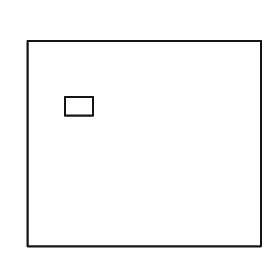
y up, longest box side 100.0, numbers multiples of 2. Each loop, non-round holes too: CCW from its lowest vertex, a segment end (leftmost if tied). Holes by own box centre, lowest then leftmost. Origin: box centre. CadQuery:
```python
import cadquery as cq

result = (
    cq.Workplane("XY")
    .moveTo(-50.0, -44.0)
    .lineTo(50.0, -44.0)
    .lineTo(50.0, 44.0)
    .lineTo(-50.0, 44.0)
    .close()
    .moveTo(-34.0, 12.0)
    .lineTo(-22.0, 12.0)
    .lineTo(-22.0, 20.0)
    .lineTo(-34.0, 20.0)
    .close()
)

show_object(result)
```